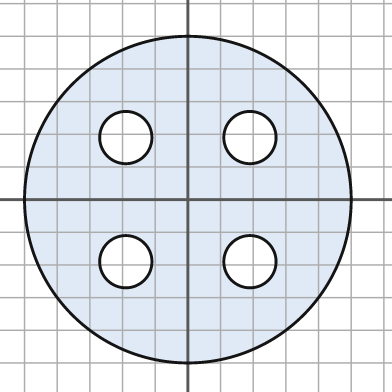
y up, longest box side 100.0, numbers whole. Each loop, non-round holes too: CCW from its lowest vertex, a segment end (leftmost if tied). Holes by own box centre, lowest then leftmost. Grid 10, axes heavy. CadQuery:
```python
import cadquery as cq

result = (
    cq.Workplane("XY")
    .moveTo(0.0, 0.0)
    .circle(50.0)
    .moveTo(-19.0, -19.0)
    .circle(8.0)
    .moveTo(19.0, -19.0)
    .circle(8.0)
    .moveTo(-19.0, 19.0)
    .circle(8.0)
    .moveTo(19.0, 19.0)
    .circle(8.0)
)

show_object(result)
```